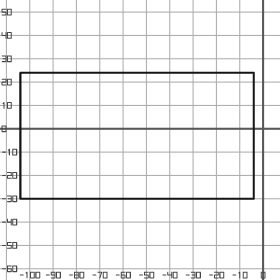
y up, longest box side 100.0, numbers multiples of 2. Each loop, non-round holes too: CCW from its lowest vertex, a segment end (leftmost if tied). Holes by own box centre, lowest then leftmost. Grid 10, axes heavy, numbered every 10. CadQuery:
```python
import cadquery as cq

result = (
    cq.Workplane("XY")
    .moveTo(-104.0, -30.0)
    .lineTo(-4.0, -30.0)
    .lineTo(-4.0, 24.0)
    .lineTo(-104.0, 24.0)
    .close()
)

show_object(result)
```